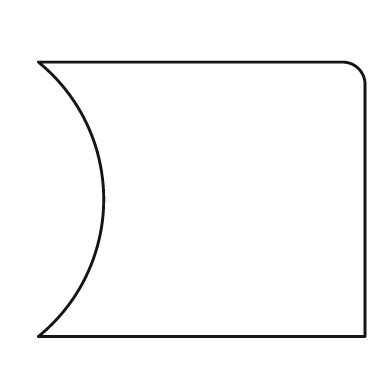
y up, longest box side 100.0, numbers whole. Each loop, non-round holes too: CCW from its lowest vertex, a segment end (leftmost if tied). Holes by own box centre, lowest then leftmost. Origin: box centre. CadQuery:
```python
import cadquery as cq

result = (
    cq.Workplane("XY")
    .moveTo(-50.0, -42.0)
    .lineTo(50.0, -42.0)
    .lineTo(50.0, 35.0)
    .threePointArc((48.0, 40.0), (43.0, 42.0))
    .lineTo(-50.0, 42.0)
    .threePointArc((-30.0, 0.0), (-50.0, -42.0))
    .close()
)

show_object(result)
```